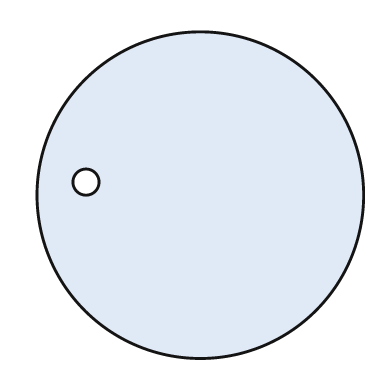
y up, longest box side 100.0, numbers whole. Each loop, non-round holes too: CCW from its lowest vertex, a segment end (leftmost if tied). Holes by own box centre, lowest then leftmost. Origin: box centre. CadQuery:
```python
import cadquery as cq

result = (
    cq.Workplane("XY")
    .moveTo(0.0, 0.0)
    .circle(50.0)
    .moveTo(-35.0, 4.0)
    .circle(4.0)
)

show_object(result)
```